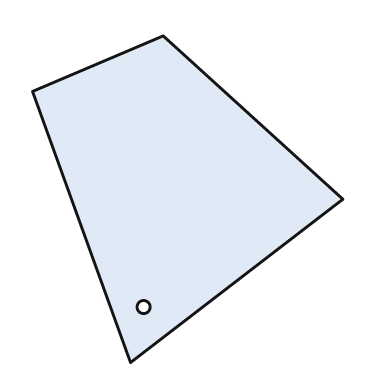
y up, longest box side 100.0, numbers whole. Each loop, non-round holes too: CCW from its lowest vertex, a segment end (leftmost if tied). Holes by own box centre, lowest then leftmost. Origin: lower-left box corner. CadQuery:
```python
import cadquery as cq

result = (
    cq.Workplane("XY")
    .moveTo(30.0, 0.0)
    .lineTo(95.0, 50.0)
    .lineTo(40.0, 100.0)
    .lineTo(0.0, 83.0)
    .close()
    .moveTo(34.0, 17.0)
    .circle(2.0)
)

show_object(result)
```